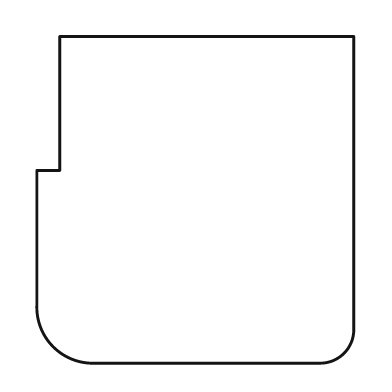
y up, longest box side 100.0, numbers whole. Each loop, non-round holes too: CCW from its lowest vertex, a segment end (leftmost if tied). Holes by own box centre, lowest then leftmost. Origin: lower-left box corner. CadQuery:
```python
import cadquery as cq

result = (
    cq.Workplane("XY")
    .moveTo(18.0, 0.0)
    .lineTo(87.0, 0.0)
    .threePointArc((94.0, 3.0), (97.0, 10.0))
    .lineTo(97.0, 100.0)
    .lineTo(7.0, 100.0)
    .lineTo(7.0, 59.0)
    .lineTo(0.0, 59.0)
    .lineTo(0.0, 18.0)
    .threePointArc((5.0, 5.0), (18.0, 0.0))
    .close()
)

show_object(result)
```